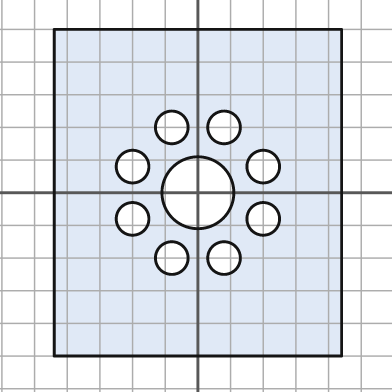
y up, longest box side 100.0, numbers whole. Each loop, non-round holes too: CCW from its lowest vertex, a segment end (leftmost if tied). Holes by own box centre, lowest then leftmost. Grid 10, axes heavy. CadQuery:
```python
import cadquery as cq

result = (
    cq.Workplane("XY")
    .moveTo(-44.0, -50.0)
    .lineTo(44.0, -50.0)
    .lineTo(44.0, 50.0)
    .lineTo(-44.0, 50.0)
    .close()
    .moveTo(-8.0, -20.0)
    .circle(5.0)
    .moveTo(8.0, -20.0)
    .circle(5.0)
    .moveTo(-20.0, -8.0)
    .circle(5.0)
    .moveTo(20.0, -8.0)
    .circle(5.0)
    .moveTo(0.0, 0.0)
    .circle(11.0)
    .moveTo(-20.0, 8.0)
    .circle(5.0)
    .moveTo(20.0, 8.0)
    .circle(5.0)
    .moveTo(-8.0, 20.0)
    .circle(5.0)
    .moveTo(8.0, 20.0)
    .circle(5.0)
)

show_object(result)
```